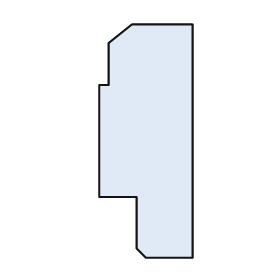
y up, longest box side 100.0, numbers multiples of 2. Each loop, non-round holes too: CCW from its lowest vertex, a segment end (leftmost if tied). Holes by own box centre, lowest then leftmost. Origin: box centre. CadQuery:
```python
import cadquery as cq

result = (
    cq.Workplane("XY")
    .moveTo(0.0, -50.0)
    .lineTo(20.0, -50.0)
    .lineTo(20.0, 50.0)
    .lineTo(-6.0, 50.0)
    .lineTo(-16.0, 42.0)
    .lineTo(-16.0, 24.0)
    .lineTo(-20.0, 24.0)
    .lineTo(-20.0, -24.0)
    .lineTo(-4.0, -24.0)
    .lineTo(-4.0, -46.0)
    .close()
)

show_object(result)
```